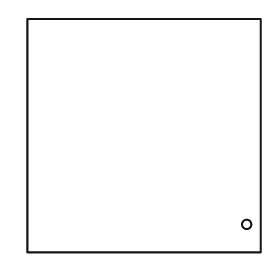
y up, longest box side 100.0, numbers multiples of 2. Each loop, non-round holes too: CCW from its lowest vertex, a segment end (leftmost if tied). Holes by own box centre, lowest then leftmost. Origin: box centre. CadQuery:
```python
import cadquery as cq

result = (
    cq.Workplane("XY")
    .moveTo(-50.0, -50.0)
    .lineTo(50.0, -50.0)
    .lineTo(50.0, 50.0)
    .lineTo(-50.0, 50.0)
    .close()
    .moveTo(44.0, -38.0)
    .circle(2.0)
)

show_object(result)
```